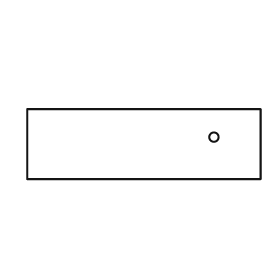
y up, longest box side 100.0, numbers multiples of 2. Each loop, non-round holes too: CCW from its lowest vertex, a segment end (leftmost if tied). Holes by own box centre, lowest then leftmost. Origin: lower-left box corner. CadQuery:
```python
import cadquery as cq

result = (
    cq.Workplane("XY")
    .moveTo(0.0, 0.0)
    .lineTo(100.0, 0.0)
    .lineTo(100.0, 30.0)
    .lineTo(0.0, 30.0)
    .close()
    .moveTo(80.0, 18.0)
    .circle(2.0)
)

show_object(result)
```